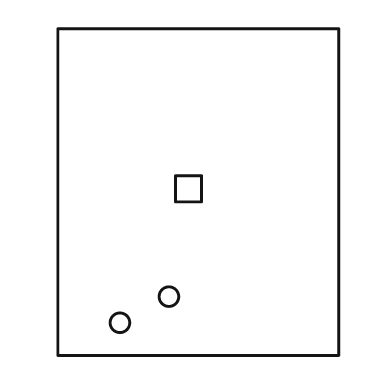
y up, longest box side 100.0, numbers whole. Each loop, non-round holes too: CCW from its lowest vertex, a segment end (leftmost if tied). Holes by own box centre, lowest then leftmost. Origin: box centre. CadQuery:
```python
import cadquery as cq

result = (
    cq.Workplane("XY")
    .moveTo(-43.0, -50.0)
    .lineTo(43.0, -50.0)
    .lineTo(43.0, 50.0)
    .lineTo(-43.0, 50.0)
    .close()
    .moveTo(-24.0, -40.0)
    .circle(3.0)
    .moveTo(-9.0, -32.0)
    .circle(3.0)
    .moveTo(-7.0, -3.0)
    .lineTo(1.0, -3.0)
    .lineTo(1.0, 5.0)
    .lineTo(-7.0, 5.0)
    .close()
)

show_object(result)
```